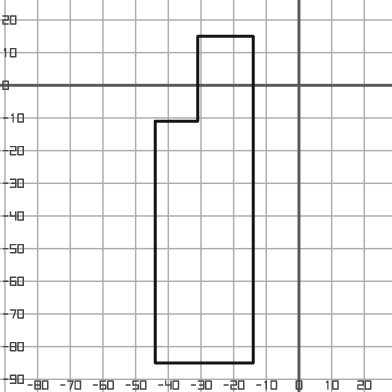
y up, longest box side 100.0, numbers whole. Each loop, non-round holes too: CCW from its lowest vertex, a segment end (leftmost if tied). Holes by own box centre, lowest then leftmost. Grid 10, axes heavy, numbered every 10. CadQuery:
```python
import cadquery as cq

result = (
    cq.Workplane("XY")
    .moveTo(-44.0, -85.0)
    .lineTo(-14.0, -85.0)
    .lineTo(-14.0, 15.0)
    .lineTo(-31.0, 15.0)
    .lineTo(-31.0, -11.0)
    .lineTo(-44.0, -11.0)
    .close()
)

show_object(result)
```